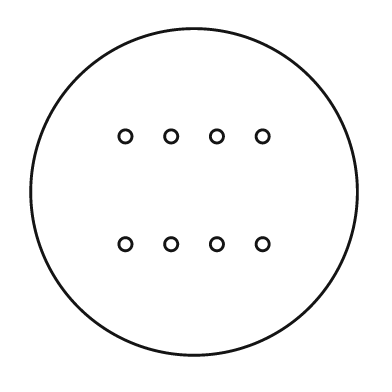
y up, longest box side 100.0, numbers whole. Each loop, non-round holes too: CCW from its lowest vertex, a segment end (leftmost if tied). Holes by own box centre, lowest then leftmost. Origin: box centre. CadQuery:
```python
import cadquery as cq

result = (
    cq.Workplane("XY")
    .moveTo(0.0, 0.0)
    .circle(50.0)
    .moveTo(-21.0, -16.0)
    .circle(2.0)
    .moveTo(-7.0, -16.0)
    .circle(2.0)
    .moveTo(7.0, -16.0)
    .circle(2.0)
    .moveTo(21.0, -16.0)
    .circle(2.0)
    .moveTo(-21.0, 17.0)
    .circle(2.0)
    .moveTo(-7.0, 17.0)
    .circle(2.0)
    .moveTo(7.0, 17.0)
    .circle(2.0)
    .moveTo(21.0, 17.0)
    .circle(2.0)
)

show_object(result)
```